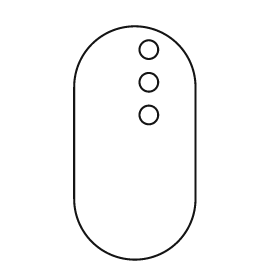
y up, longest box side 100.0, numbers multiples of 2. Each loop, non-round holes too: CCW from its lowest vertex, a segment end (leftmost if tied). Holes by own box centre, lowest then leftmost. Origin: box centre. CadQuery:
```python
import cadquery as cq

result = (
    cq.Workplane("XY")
    .moveTo(-26.0, -24.0)
    .threePointArc((0.0, -50.0), (26.0, -24.0))
    .lineTo(26.0, 24.0)
    .threePointArc((0.0, 50.0), (-26.0, 24.0))
    .close()
    .moveTo(6.0, 12.0)
    .circle(4.0)
    .moveTo(6.0, 26.0)
    .circle(4.0)
    .moveTo(6.0, 40.0)
    .circle(4.0)
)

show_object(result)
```